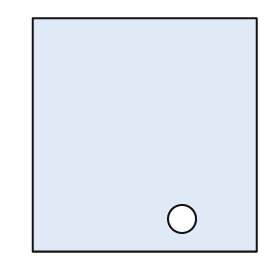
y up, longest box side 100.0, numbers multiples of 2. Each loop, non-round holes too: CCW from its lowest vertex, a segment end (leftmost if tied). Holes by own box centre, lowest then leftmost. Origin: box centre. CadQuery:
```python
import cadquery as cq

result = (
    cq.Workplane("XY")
    .moveTo(-48.0, -50.0)
    .lineTo(48.0, -50.0)
    .lineTo(48.0, 50.0)
    .lineTo(-48.0, 50.0)
    .close()
    .moveTo(16.0, -36.0)
    .circle(6.0)
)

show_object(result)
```